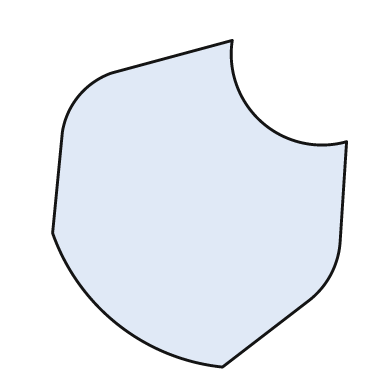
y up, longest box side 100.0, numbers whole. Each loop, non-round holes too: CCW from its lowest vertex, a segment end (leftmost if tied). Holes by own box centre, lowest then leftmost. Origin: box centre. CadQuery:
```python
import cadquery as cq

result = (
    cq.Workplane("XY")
    .moveTo(7.0, -50.0)
    .lineTo(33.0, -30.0)
    .threePointArc((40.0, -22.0), (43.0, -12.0))
    .lineTo(45.0, 19.0)
    .threePointArc((19.0, 25.0), (10.0, 50.0))
    .lineTo(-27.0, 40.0)
    .threePointArc((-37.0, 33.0), (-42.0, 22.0))
    .lineTo(-45.0, -9.0)
    .threePointArc((-25.0, -37.0), (7.0, -50.0))
    .close()
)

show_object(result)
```